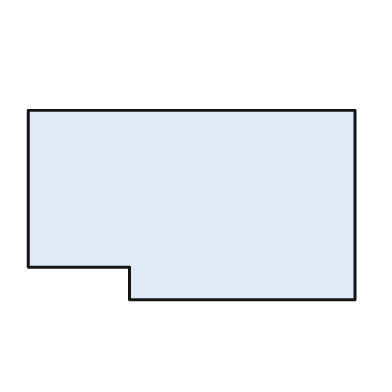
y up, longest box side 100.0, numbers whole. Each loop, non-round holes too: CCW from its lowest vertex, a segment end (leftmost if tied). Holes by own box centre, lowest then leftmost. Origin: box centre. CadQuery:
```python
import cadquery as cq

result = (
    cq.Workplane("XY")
    .moveTo(-19.0, -29.0)
    .lineTo(50.0, -29.0)
    .lineTo(50.0, 29.0)
    .lineTo(-50.0, 29.0)
    .lineTo(-50.0, -19.0)
    .lineTo(-19.0, -19.0)
    .close()
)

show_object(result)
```